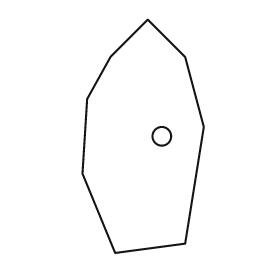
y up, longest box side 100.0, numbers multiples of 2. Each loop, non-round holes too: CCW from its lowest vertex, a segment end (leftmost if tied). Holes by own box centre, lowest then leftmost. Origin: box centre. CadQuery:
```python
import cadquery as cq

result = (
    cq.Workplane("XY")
    .moveTo(-12.0, -50.0)
    .lineTo(18.0, -46.0)
    .lineTo(26.0, 4.0)
    .lineTo(18.0, 34.0)
    .lineTo(2.0, 50.0)
    .lineTo(-14.0, 34.0)
    .lineTo(-24.0, 16.0)
    .lineTo(-26.0, -16.0)
    .close()
    .moveTo(8.0, 0.0)
    .circle(4.0)
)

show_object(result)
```